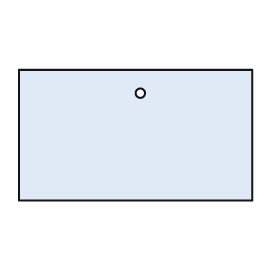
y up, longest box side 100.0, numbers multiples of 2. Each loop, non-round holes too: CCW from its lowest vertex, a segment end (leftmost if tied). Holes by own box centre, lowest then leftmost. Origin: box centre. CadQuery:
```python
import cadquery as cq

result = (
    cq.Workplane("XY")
    .moveTo(-50.0, -28.0)
    .lineTo(50.0, -28.0)
    .lineTo(50.0, 28.0)
    .lineTo(-50.0, 28.0)
    .close()
    .moveTo(2.0, 18.0)
    .circle(2.0)
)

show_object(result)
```